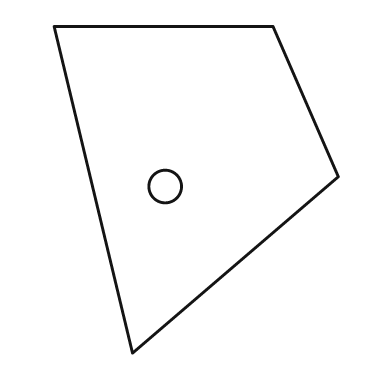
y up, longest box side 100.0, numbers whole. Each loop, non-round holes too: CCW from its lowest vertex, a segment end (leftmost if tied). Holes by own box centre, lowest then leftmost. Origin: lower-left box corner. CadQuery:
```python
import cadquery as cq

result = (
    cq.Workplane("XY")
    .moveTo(24.0, 0.0)
    .lineTo(87.0, 54.0)
    .lineTo(67.0, 100.0)
    .lineTo(0.0, 100.0)
    .close()
    .moveTo(34.0, 51.0)
    .circle(5.0)
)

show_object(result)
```